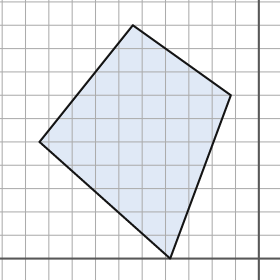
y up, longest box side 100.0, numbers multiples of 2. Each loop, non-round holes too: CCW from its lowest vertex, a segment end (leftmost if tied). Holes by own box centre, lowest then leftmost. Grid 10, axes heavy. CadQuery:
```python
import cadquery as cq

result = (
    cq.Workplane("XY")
    .moveTo(-38.0, 0.0)
    .lineTo(-12.0, 70.0)
    .lineTo(-54.0, 100.0)
    .lineTo(-94.0, 50.0)
    .close()
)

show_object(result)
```